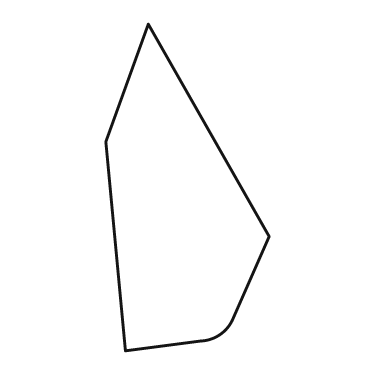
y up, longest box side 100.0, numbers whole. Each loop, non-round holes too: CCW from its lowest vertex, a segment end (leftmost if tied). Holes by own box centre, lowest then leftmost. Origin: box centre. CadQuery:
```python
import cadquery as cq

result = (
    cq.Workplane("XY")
    .moveTo(-19.0, -50.0)
    .lineTo(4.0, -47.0)
    .threePointArc((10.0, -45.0), (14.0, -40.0))
    .lineTo(25.0, -15.0)
    .lineTo(-12.0, 50.0)
    .lineTo(-25.0, 14.0)
    .close()
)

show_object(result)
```